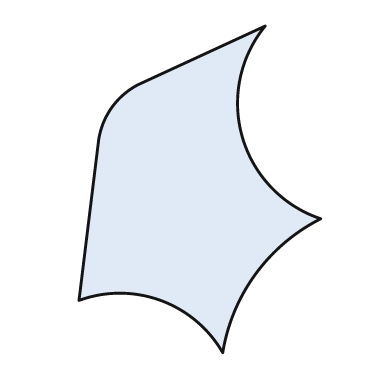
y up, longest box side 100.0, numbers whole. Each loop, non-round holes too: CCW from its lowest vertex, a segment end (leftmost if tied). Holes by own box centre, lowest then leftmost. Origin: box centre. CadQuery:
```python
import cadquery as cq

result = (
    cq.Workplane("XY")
    .moveTo(7.0, -50.0)
    .threePointArc((17.0, -26.0), (37.0, -9.0))
    .threePointArc((13.0, 16.0), (20.0, 50.0))
    .lineTo(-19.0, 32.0)
    .threePointArc((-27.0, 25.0), (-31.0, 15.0))
    .lineTo(-37.0, -34.0)
    .threePointArc((-12.0, -34.0), (7.0, -50.0))
    .close()
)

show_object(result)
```